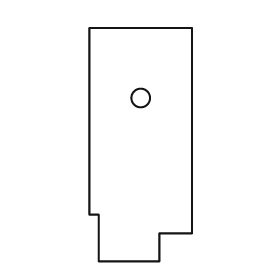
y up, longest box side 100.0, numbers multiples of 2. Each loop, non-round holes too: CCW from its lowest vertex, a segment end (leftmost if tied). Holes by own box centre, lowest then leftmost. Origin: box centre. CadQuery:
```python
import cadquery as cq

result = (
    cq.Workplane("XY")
    .moveTo(-18.0, -50.0)
    .lineTo(8.0, -50.0)
    .lineTo(8.0, -38.0)
    .lineTo(22.0, -38.0)
    .lineTo(22.0, 50.0)
    .lineTo(-22.0, 50.0)
    .lineTo(-22.0, -30.0)
    .lineTo(-18.0, -30.0)
    .close()
    .moveTo(0.0, 20.0)
    .circle(4.0)
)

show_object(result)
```